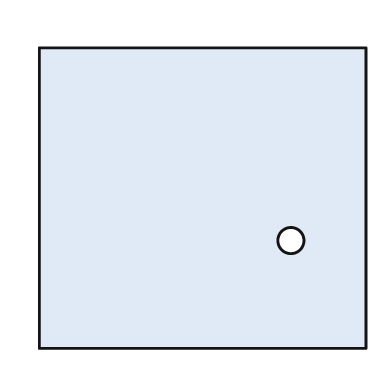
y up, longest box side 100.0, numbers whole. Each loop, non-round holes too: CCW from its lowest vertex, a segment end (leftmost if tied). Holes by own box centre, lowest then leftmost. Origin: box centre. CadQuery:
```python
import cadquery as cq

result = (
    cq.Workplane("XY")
    .moveTo(-50.0, -46.0)
    .lineTo(50.0, -46.0)
    .lineTo(50.0, 46.0)
    .lineTo(-50.0, 46.0)
    .close()
    .moveTo(27.0, -13.0)
    .circle(4.0)
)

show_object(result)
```